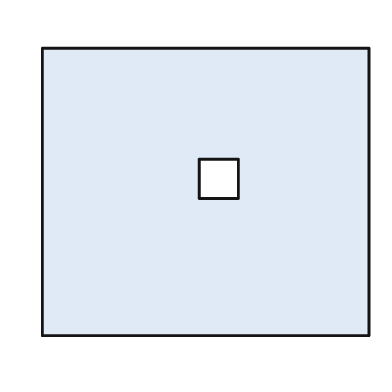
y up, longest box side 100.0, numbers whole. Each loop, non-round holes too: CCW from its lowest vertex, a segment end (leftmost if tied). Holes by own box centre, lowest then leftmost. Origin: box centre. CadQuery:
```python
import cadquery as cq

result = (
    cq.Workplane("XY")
    .moveTo(-50.0, -44.0)
    .lineTo(50.0, -44.0)
    .lineTo(50.0, 44.0)
    .lineTo(-50.0, 44.0)
    .close()
    .moveTo(-2.0, -2.0)
    .lineTo(10.0, -2.0)
    .lineTo(10.0, 10.0)
    .lineTo(-2.0, 10.0)
    .close()
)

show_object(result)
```